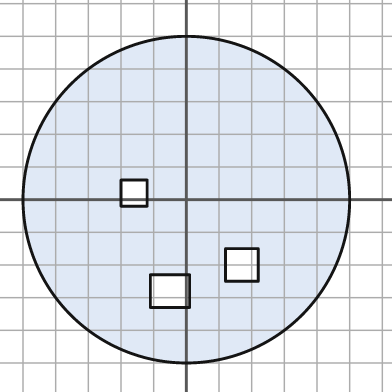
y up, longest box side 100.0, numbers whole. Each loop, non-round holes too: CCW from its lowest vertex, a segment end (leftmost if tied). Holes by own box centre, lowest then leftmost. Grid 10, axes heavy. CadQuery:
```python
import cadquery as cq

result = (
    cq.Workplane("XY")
    .moveTo(0.0, 0.0)
    .circle(50.0)
    .moveTo(-11.0, -33.0)
    .lineTo(1.0, -33.0)
    .lineTo(1.0, -23.0)
    .lineTo(-11.0, -23.0)
    .close()
    .moveTo(12.0, -25.0)
    .lineTo(22.0, -25.0)
    .lineTo(22.0, -15.0)
    .lineTo(12.0, -15.0)
    .close()
    .moveTo(-20.0, -2.0)
    .lineTo(-12.0, -2.0)
    .lineTo(-12.0, 6.0)
    .lineTo(-20.0, 6.0)
    .close()
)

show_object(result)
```